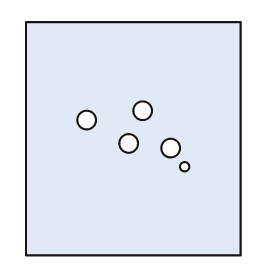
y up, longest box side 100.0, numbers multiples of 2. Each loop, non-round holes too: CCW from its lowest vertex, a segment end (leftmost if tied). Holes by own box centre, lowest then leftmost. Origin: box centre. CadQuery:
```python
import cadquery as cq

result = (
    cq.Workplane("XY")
    .moveTo(-46.0, -50.0)
    .lineTo(46.0, -50.0)
    .lineTo(46.0, 50.0)
    .lineTo(-46.0, 50.0)
    .close()
    .moveTo(22.0, -12.0)
    .circle(2.0)
    .moveTo(16.0, -4.0)
    .circle(4.0)
    .moveTo(-2.0, -2.0)
    .circle(4.0)
    .moveTo(-20.0, 8.0)
    .circle(4.0)
    .moveTo(4.0, 12.0)
    .circle(4.0)
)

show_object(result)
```